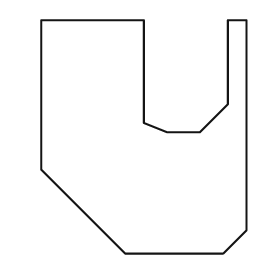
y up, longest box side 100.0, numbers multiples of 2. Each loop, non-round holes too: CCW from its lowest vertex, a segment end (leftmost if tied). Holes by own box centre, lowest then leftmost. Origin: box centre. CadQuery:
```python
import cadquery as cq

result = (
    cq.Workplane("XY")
    .moveTo(-8.0, -50.0)
    .lineTo(34.0, -50.0)
    .lineTo(44.0, -40.0)
    .lineTo(44.0, 50.0)
    .lineTo(36.0, 50.0)
    .lineTo(36.0, 14.0)
    .lineTo(24.0, 2.0)
    .lineTo(10.0, 2.0)
    .lineTo(0.0, 6.0)
    .lineTo(0.0, 50.0)
    .lineTo(-44.0, 50.0)
    .lineTo(-44.0, -14.0)
    .close()
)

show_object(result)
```